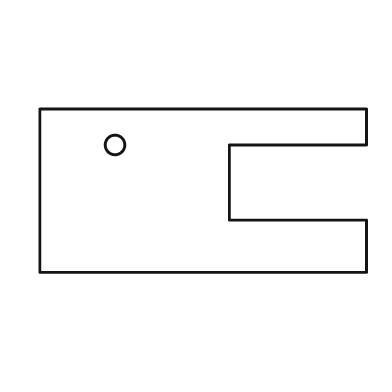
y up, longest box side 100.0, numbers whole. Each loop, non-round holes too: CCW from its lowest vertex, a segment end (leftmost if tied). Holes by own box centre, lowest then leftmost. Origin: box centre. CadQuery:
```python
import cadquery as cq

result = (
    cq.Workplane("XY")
    .moveTo(-50.0, -25.0)
    .lineTo(50.0, -25.0)
    .lineTo(50.0, -9.0)
    .lineTo(8.0, -9.0)
    .lineTo(8.0, 14.0)
    .lineTo(50.0, 14.0)
    .lineTo(50.0, 25.0)
    .lineTo(-50.0, 25.0)
    .close()
    .moveTo(-27.0, 14.0)
    .circle(3.0)
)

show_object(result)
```